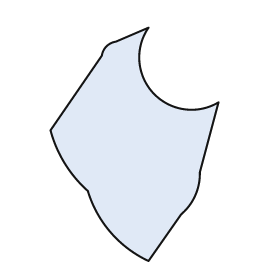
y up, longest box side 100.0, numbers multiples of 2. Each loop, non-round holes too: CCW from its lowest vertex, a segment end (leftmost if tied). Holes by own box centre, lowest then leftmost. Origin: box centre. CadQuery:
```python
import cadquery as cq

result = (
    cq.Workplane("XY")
    .moveTo(6.0, -50.0)
    .lineTo(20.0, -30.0)
    .threePointArc((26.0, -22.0), (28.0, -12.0))
    .lineTo(36.0, 18.0)
    .threePointArc((8.0, 22.0), (6.0, 50.0))
    .lineTo(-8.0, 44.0)
    .threePointArc((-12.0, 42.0), (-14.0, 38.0))
    .lineTo(-36.0, 6.0)
    .threePointArc((-30.0, -8.0), (-20.0, -20.0))
    .threePointArc((-10.0, -38.0), (6.0, -50.0))
    .close()
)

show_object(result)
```